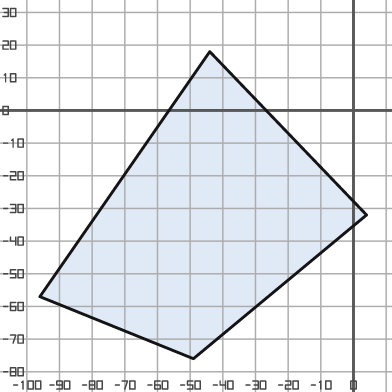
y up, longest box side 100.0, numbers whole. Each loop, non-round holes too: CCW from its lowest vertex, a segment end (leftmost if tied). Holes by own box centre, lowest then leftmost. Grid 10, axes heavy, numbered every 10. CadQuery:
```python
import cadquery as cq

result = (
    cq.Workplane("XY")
    .moveTo(-49.0, -76.0)
    .lineTo(4.0, -32.0)
    .lineTo(-44.0, 18.0)
    .lineTo(-96.0, -57.0)
    .close()
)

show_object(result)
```